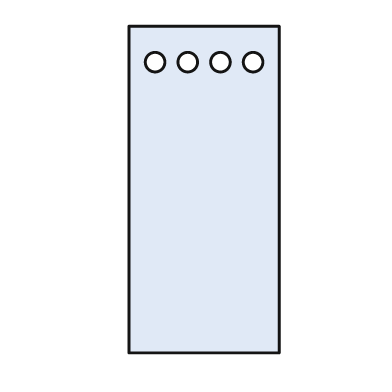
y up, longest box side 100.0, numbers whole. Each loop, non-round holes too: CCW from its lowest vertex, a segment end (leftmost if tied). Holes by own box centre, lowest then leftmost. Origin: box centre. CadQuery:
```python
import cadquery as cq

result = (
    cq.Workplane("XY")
    .moveTo(-23.0, -50.0)
    .lineTo(23.0, -50.0)
    .lineTo(23.0, 50.0)
    .lineTo(-23.0, 50.0)
    .close()
    .moveTo(-15.0, 39.0)
    .circle(3.0)
    .moveTo(-5.0, 39.0)
    .circle(3.0)
    .moveTo(5.0, 39.0)
    .circle(3.0)
    .moveTo(15.0, 39.0)
    .circle(3.0)
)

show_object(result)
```